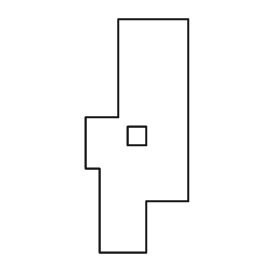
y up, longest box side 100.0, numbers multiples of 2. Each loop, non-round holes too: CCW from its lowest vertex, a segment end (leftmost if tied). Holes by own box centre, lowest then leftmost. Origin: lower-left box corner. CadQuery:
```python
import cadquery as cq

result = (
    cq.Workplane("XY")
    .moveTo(6.0, 0.0)
    .lineTo(26.0, 0.0)
    .lineTo(26.0, 22.0)
    .lineTo(44.0, 22.0)
    .lineTo(44.0, 100.0)
    .lineTo(14.0, 100.0)
    .lineTo(14.0, 58.0)
    .lineTo(0.0, 58.0)
    .lineTo(0.0, 36.0)
    .lineTo(6.0, 36.0)
    .close()
    .moveTo(18.0, 46.0)
    .lineTo(26.0, 46.0)
    .lineTo(26.0, 54.0)
    .lineTo(18.0, 54.0)
    .close()
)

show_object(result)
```